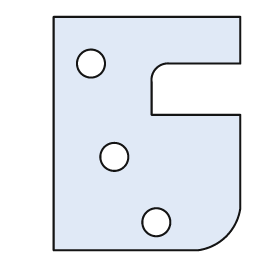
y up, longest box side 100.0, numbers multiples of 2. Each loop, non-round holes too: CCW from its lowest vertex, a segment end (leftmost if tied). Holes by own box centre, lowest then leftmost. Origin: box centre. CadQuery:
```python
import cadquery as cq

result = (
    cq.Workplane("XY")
    .moveTo(-40.0, -50.0)
    .lineTo(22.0, -50.0)
    .threePointArc((34.0, -44.0), (40.0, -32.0))
    .lineTo(40.0, 8.0)
    .lineTo(2.0, 8.0)
    .lineTo(2.0, 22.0)
    .threePointArc((4.0, 28.0), (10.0, 30.0))
    .lineTo(40.0, 30.0)
    .lineTo(40.0, 50.0)
    .lineTo(-40.0, 50.0)
    .close()
    .moveTo(4.0, -38.0)
    .circle(6.0)
    .moveTo(-14.0, -10.0)
    .circle(6.0)
    .moveTo(-24.0, 30.0)
    .circle(6.0)
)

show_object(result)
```